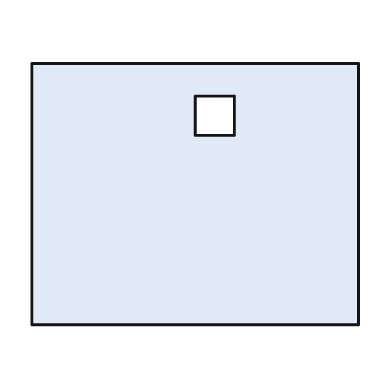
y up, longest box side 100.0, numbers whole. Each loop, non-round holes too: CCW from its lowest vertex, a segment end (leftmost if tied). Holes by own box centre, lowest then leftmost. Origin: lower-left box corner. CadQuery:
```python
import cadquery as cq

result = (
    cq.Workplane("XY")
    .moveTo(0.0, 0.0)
    .lineTo(100.0, 0.0)
    .lineTo(100.0, 80.0)
    .lineTo(0.0, 80.0)
    .close()
    .moveTo(50.0, 58.0)
    .lineTo(62.0, 58.0)
    .lineTo(62.0, 70.0)
    .lineTo(50.0, 70.0)
    .close()
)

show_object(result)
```